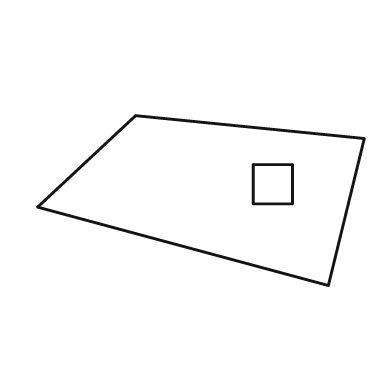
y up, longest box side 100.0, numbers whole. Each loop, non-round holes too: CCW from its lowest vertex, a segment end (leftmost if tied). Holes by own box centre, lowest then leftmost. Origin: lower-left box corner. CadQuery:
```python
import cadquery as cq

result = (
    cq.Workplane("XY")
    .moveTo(89.0, 0.0)
    .lineTo(100.0, 45.0)
    .lineTo(30.0, 52.0)
    .lineTo(0.0, 24.0)
    .close()
    .moveTo(66.0, 25.0)
    .lineTo(78.0, 25.0)
    .lineTo(78.0, 37.0)
    .lineTo(66.0, 37.0)
    .close()
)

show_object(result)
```